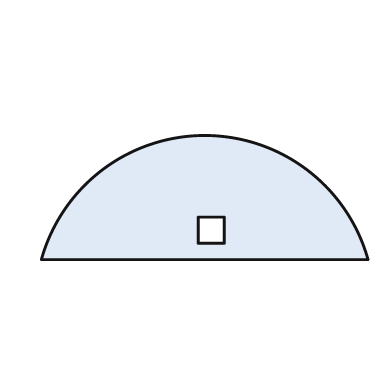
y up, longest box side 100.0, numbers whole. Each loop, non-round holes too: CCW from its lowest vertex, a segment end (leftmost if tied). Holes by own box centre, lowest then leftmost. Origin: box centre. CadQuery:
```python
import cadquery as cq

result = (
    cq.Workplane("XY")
    .moveTo(-50.0, -19.0)
    .lineTo(50.0, -19.0)
    .threePointArc((0.0, 19.0), (-50.0, -19.0))
    .close()
    .moveTo(-2.0, -14.0)
    .lineTo(6.0, -14.0)
    .lineTo(6.0, -6.0)
    .lineTo(-2.0, -6.0)
    .close()
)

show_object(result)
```